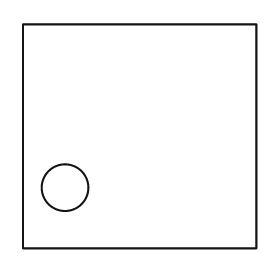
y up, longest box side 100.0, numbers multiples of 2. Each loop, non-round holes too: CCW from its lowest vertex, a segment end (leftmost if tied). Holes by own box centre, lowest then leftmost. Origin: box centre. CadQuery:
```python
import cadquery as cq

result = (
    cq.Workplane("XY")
    .moveTo(-50.0, -48.0)
    .lineTo(50.0, -48.0)
    .lineTo(50.0, 48.0)
    .lineTo(-50.0, 48.0)
    .close()
    .moveTo(-32.0, -22.0)
    .circle(10.0)
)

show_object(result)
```